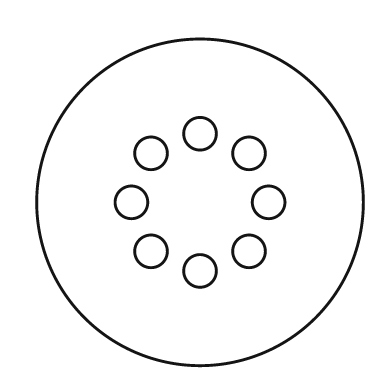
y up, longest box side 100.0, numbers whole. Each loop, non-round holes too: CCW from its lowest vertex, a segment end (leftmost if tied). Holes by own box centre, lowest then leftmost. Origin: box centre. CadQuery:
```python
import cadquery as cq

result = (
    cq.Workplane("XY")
    .moveTo(0.0, 0.0)
    .circle(50.0)
    .moveTo(0.0, -21.0)
    .circle(5.0)
    .moveTo(-15.0, -15.0)
    .circle(5.0)
    .moveTo(15.0, -15.0)
    .circle(5.0)
    .moveTo(-21.0, 0.0)
    .circle(5.0)
    .moveTo(21.0, 0.0)
    .circle(5.0)
    .moveTo(-15.0, 15.0)
    .circle(5.0)
    .moveTo(15.0, 15.0)
    .circle(5.0)
    .moveTo(0.0, 21.0)
    .circle(5.0)
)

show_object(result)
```